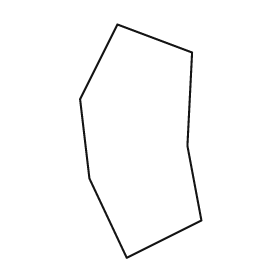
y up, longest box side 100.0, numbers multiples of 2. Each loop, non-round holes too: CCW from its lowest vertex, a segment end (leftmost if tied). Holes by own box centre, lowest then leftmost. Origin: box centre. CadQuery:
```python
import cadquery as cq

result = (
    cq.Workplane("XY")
    .moveTo(-6.0, -50.0)
    .lineTo(26.0, -34.0)
    .lineTo(20.0, -2.0)
    .lineTo(22.0, 38.0)
    .lineTo(-10.0, 50.0)
    .lineTo(-26.0, 18.0)
    .lineTo(-22.0, -16.0)
    .close()
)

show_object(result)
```